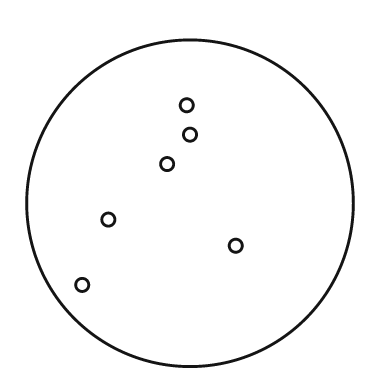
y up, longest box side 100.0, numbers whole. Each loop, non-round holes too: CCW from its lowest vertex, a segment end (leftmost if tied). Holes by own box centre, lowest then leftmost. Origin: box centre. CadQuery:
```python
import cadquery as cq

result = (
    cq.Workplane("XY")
    .moveTo(0.0, 0.0)
    .circle(50.0)
    .moveTo(-33.0, -25.0)
    .circle(2.0)
    .moveTo(14.0, -13.0)
    .circle(2.0)
    .moveTo(-25.0, -5.0)
    .circle(2.0)
    .moveTo(-7.0, 12.0)
    .circle(2.0)
    .moveTo(0.0, 21.0)
    .circle(2.0)
    .moveTo(-1.0, 30.0)
    .circle(2.0)
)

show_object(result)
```